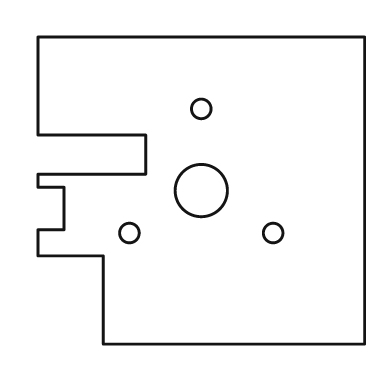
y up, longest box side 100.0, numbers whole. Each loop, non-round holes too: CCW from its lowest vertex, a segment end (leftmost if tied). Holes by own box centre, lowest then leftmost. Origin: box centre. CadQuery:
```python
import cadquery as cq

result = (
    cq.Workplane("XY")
    .moveTo(-30.0, -47.0)
    .lineTo(50.0, -47.0)
    .lineTo(50.0, 47.0)
    .lineTo(-50.0, 47.0)
    .lineTo(-50.0, 17.0)
    .lineTo(-17.0, 17.0)
    .lineTo(-17.0, 5.0)
    .lineTo(-50.0, 5.0)
    .lineTo(-50.0, 1.0)
    .lineTo(-42.0, 1.0)
    .lineTo(-42.0, -12.0)
    .lineTo(-50.0, -12.0)
    .lineTo(-50.0, -20.0)
    .lineTo(-30.0, -20.0)
    .close()
    .moveTo(-22.0, -13.0)
    .circle(3.0)
    .moveTo(22.0, -13.0)
    .circle(3.0)
    .moveTo(0.0, 0.0)
    .circle(8.0)
    .moveTo(0.0, 25.0)
    .circle(3.0)
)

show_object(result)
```